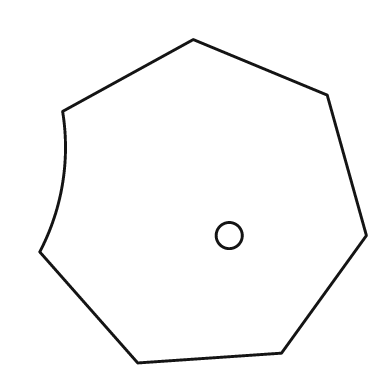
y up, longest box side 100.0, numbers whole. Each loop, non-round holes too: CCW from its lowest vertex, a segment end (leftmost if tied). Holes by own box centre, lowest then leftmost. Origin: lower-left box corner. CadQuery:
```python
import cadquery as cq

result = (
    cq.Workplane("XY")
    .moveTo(30.0, 0.0)
    .lineTo(74.0, 3.0)
    .lineTo(100.0, 39.0)
    .lineTo(88.0, 82.0)
    .lineTo(47.0, 99.0)
    .lineTo(7.0, 77.0)
    .threePointArc((7.0, 55.0), (0.0, 34.0))
    .close()
    .moveTo(58.0, 39.0)
    .circle(4.0)
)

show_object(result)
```